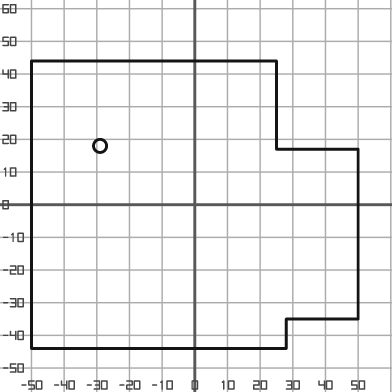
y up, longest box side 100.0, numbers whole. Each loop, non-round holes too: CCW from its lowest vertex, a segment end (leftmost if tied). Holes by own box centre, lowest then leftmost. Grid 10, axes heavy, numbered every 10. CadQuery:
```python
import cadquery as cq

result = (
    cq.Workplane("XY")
    .moveTo(-50.0, -44.0)
    .lineTo(28.0, -44.0)
    .lineTo(28.0, -35.0)
    .lineTo(50.0, -35.0)
    .lineTo(50.0, 17.0)
    .lineTo(25.0, 17.0)
    .lineTo(25.0, 44.0)
    .lineTo(-50.0, 44.0)
    .close()
    .moveTo(-29.0, 18.0)
    .circle(2.0)
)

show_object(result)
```